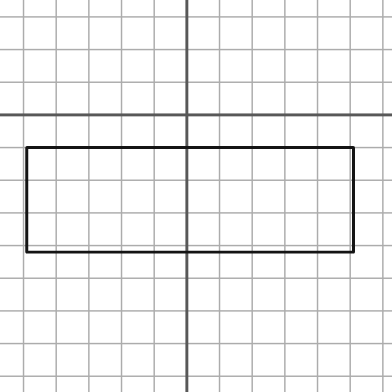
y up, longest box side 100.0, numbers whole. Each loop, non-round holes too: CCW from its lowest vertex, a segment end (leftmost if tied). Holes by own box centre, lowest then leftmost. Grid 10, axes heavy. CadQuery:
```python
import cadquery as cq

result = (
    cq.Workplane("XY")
    .moveTo(-49.0, -42.0)
    .lineTo(51.0, -42.0)
    .lineTo(51.0, -10.0)
    .lineTo(-49.0, -10.0)
    .close()
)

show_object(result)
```